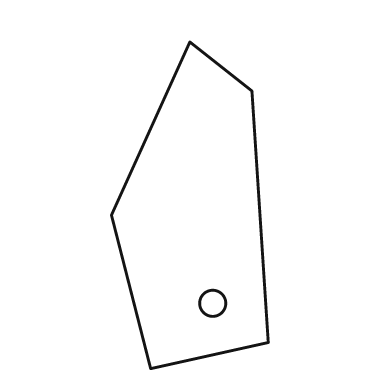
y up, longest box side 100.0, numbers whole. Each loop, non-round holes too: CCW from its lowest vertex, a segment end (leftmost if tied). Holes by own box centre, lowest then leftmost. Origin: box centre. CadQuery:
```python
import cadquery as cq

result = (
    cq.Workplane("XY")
    .moveTo(-12.0, -50.0)
    .lineTo(24.0, -42.0)
    .lineTo(19.0, 35.0)
    .lineTo(0.0, 50.0)
    .lineTo(-24.0, -3.0)
    .close()
    .moveTo(7.0, -30.0)
    .circle(4.0)
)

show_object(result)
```